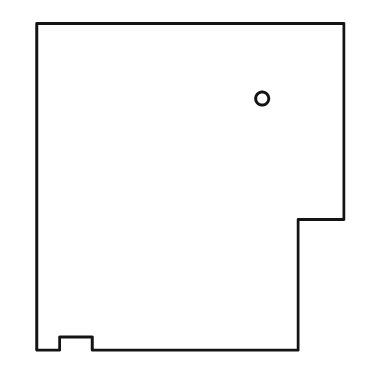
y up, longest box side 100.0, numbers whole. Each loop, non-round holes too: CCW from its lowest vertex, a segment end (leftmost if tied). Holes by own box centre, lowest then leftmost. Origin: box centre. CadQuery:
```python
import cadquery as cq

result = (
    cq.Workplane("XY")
    .moveTo(-47.0, -50.0)
    .lineTo(-40.0, -50.0)
    .lineTo(-40.0, -46.0)
    .lineTo(-30.0, -46.0)
    .lineTo(-30.0, -50.0)
    .lineTo(33.0, -50.0)
    .lineTo(33.0, -10.0)
    .lineTo(47.0, -10.0)
    .lineTo(47.0, 50.0)
    .lineTo(-47.0, 50.0)
    .close()
    .moveTo(22.0, 27.0)
    .circle(2.0)
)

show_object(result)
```